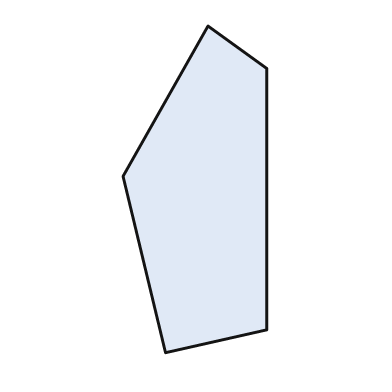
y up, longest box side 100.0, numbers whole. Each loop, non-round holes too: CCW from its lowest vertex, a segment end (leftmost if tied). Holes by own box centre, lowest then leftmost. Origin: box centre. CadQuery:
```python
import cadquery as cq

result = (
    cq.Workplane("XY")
    .moveTo(-9.0, -50.0)
    .lineTo(22.0, -43.0)
    .lineTo(22.0, 37.0)
    .lineTo(4.0, 50.0)
    .lineTo(-22.0, 4.0)
    .close()
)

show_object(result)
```